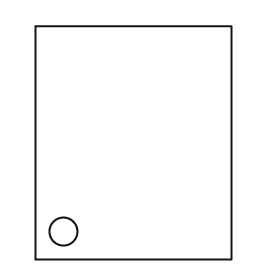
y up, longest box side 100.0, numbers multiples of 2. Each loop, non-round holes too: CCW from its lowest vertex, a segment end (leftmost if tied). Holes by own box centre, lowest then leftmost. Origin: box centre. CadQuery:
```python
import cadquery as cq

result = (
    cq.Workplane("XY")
    .moveTo(-42.0, -50.0)
    .lineTo(42.0, -50.0)
    .lineTo(42.0, 50.0)
    .lineTo(-42.0, 50.0)
    .close()
    .moveTo(-30.0, -38.0)
    .circle(6.0)
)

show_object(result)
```